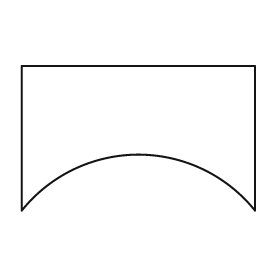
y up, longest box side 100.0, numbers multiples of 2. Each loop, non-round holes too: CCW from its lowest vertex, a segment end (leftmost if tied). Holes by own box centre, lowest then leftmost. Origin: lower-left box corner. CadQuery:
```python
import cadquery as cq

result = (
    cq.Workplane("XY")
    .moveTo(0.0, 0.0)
    .threePointArc((50.0, 24.0), (100.0, 0.0))
    .lineTo(100.0, 62.0)
    .lineTo(0.0, 62.0)
    .close()
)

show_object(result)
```